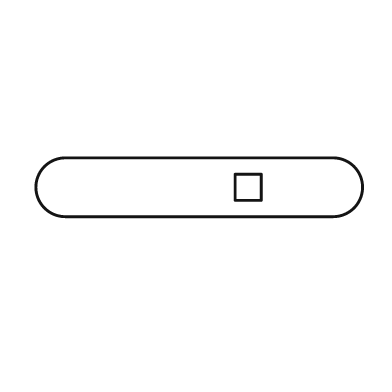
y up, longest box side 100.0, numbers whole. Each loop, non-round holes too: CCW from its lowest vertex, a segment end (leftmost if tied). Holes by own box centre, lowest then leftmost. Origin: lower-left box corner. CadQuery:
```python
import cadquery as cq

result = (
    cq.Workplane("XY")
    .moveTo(9.0, 0.0)
    .lineTo(91.0, 0.0)
    .threePointArc((100.0, 9.0), (91.0, 18.0))
    .lineTo(9.0, 18.0)
    .threePointArc((0.0, 9.0), (9.0, 0.0))
    .close()
    .moveTo(61.0, 5.0)
    .lineTo(69.0, 5.0)
    .lineTo(69.0, 13.0)
    .lineTo(61.0, 13.0)
    .close()
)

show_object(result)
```